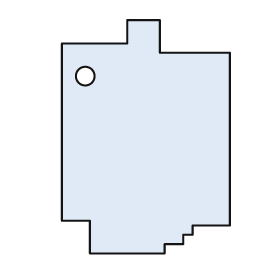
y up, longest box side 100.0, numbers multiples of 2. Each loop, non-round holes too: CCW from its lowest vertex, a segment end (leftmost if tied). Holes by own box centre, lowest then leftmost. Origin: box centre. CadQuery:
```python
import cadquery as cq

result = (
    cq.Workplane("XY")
    .moveTo(-24.0, -50.0)
    .lineTo(8.0, -50.0)
    .lineTo(8.0, -46.0)
    .lineTo(16.0, -46.0)
    .lineTo(16.0, -42.0)
    .lineTo(20.0, -42.0)
    .lineTo(20.0, -38.0)
    .lineTo(36.0, -38.0)
    .lineTo(36.0, 36.0)
    .lineTo(6.0, 36.0)
    .lineTo(6.0, 50.0)
    .lineTo(-8.0, 50.0)
    .lineTo(-8.0, 40.0)
    .lineTo(-36.0, 40.0)
    .lineTo(-36.0, -36.0)
    .lineTo(-24.0, -36.0)
    .close()
    .moveTo(-26.0, 26.0)
    .circle(4.0)
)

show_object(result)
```